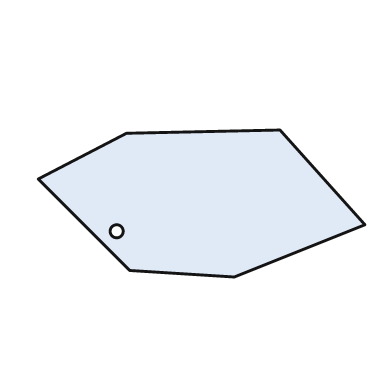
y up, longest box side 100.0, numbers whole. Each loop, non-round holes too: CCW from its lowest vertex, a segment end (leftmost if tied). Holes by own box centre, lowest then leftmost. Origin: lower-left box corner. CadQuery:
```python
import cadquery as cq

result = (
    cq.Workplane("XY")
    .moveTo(60.0, 0.0)
    .lineTo(100.0, 16.0)
    .lineTo(74.0, 45.0)
    .lineTo(27.0, 44.0)
    .lineTo(0.0, 30.0)
    .lineTo(28.0, 2.0)
    .close()
    .moveTo(24.0, 14.0)
    .circle(2.0)
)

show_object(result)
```